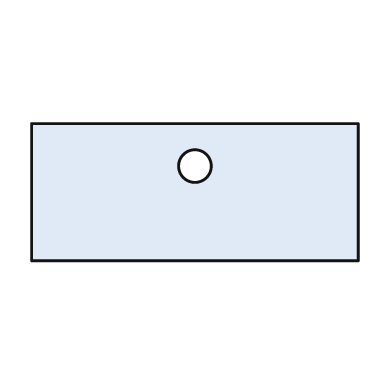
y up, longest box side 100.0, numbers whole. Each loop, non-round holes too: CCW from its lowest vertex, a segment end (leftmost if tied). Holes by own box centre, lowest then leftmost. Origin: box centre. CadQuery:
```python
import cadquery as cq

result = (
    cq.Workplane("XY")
    .moveTo(-50.0, -21.0)
    .lineTo(50.0, -21.0)
    .lineTo(50.0, 21.0)
    .lineTo(-50.0, 21.0)
    .close()
    .moveTo(0.0, 8.0)
    .circle(5.0)
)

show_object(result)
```